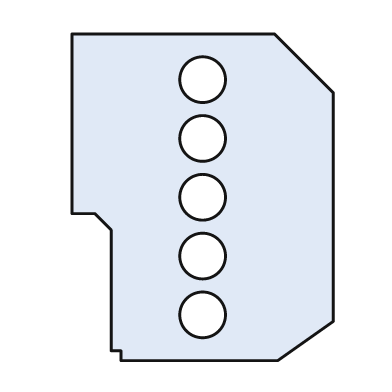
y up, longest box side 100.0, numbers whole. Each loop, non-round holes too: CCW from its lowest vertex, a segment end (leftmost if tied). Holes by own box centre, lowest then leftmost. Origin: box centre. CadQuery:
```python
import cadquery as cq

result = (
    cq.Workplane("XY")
    .moveTo(-25.0, -50.0)
    .lineTo(23.0, -50.0)
    .lineTo(40.0, -38.0)
    .lineTo(40.0, 32.0)
    .lineTo(22.0, 50.0)
    .lineTo(-40.0, 50.0)
    .lineTo(-40.0, -5.0)
    .lineTo(-33.0, -5.0)
    .lineTo(-28.0, -10.0)
    .lineTo(-28.0, -47.0)
    .lineTo(-25.0, -47.0)
    .close()
    .moveTo(0.0, -36.0)
    .circle(7.0)
    .moveTo(0.0, -18.0)
    .circle(7.0)
    .moveTo(0.0, 0.0)
    .circle(7.0)
    .moveTo(0.0, 18.0)
    .circle(7.0)
    .moveTo(0.0, 36.0)
    .circle(7.0)
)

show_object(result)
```